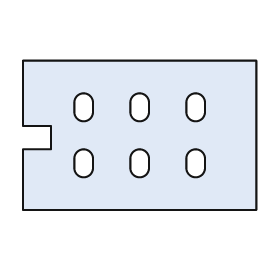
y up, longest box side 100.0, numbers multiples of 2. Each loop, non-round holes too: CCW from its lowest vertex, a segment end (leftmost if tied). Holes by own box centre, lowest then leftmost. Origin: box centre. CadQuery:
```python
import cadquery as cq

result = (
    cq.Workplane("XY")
    .moveTo(-50.0, -32.0)
    .lineTo(50.0, -32.0)
    .lineTo(50.0, 32.0)
    .lineTo(-50.0, 32.0)
    .lineTo(-50.0, 4.0)
    .lineTo(-38.0, 4.0)
    .lineTo(-38.0, -6.0)
    .lineTo(-50.0, -6.0)
    .close()
    .moveTo(-28.0, -14.0)
    .threePointArc((-24.0, -18.0), (-20.0, -14.0))
    .lineTo(-20.0, -10.0)
    .threePointArc((-24.0, -6.0), (-28.0, -10.0))
    .close()
    .moveTo(-4.0, -14.0)
    .threePointArc((0.0, -18.0), (4.0, -14.0))
    .lineTo(4.0, -10.0)
    .threePointArc((0.0, -6.0), (-4.0, -10.0))
    .close()
    .moveTo(20.0, -14.0)
    .threePointArc((24.0, -18.0), (28.0, -14.0))
    .lineTo(28.0, -10.0)
    .threePointArc((24.0, -6.0), (20.0, -10.0))
    .close()
    .moveTo(-28.0, 10.0)
    .threePointArc((-24.0, 6.0), (-20.0, 10.0))
    .lineTo(-20.0, 14.0)
    .threePointArc((-24.0, 18.0), (-28.0, 14.0))
    .close()
    .moveTo(-4.0, 10.0)
    .threePointArc((0.0, 6.0), (4.0, 10.0))
    .lineTo(4.0, 14.0)
    .threePointArc((0.0, 18.0), (-4.0, 14.0))
    .close()
    .moveTo(20.0, 10.0)
    .threePointArc((24.0, 6.0), (28.0, 10.0))
    .lineTo(28.0, 14.0)
    .threePointArc((24.0, 18.0), (20.0, 14.0))
    .close()
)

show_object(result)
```